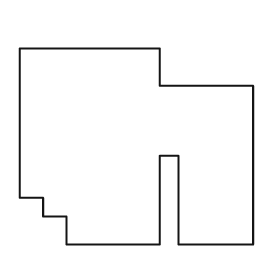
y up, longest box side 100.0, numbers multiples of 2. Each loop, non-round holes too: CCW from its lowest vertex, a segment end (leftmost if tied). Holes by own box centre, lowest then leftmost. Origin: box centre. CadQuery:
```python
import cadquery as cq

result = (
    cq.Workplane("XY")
    .moveTo(-30.0, -42.0)
    .lineTo(10.0, -42.0)
    .lineTo(10.0, -4.0)
    .lineTo(18.0, -4.0)
    .lineTo(18.0, -42.0)
    .lineTo(50.0, -42.0)
    .lineTo(50.0, 26.0)
    .lineTo(10.0, 26.0)
    .lineTo(10.0, 42.0)
    .lineTo(-50.0, 42.0)
    .lineTo(-50.0, -22.0)
    .lineTo(-40.0, -22.0)
    .lineTo(-40.0, -30.0)
    .lineTo(-30.0, -30.0)
    .close()
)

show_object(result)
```